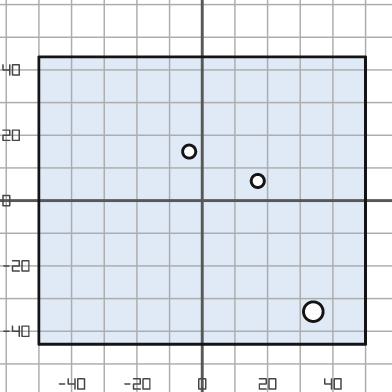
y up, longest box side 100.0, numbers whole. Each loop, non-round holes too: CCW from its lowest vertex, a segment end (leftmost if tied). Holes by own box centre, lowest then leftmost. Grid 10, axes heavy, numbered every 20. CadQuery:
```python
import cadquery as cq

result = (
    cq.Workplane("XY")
    .moveTo(-50.0, -44.0)
    .lineTo(50.0, -44.0)
    .lineTo(50.0, 44.0)
    .lineTo(-50.0, 44.0)
    .close()
    .moveTo(34.0, -34.0)
    .circle(3.0)
    .moveTo(17.0, 6.0)
    .circle(2.0)
    .moveTo(-4.0, 15.0)
    .circle(2.0)
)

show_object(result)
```